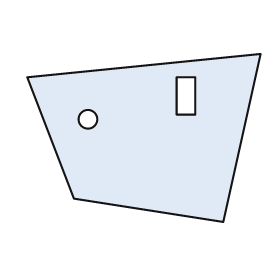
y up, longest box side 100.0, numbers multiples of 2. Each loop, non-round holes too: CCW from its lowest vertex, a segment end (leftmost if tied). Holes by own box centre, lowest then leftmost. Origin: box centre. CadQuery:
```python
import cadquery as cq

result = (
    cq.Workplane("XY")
    .moveTo(34.0, -36.0)
    .lineTo(50.0, 36.0)
    .lineTo(-50.0, 26.0)
    .lineTo(-30.0, -26.0)
    .close()
    .moveTo(-24.0, 8.0)
    .circle(4.0)
    .moveTo(14.0, 10.0)
    .lineTo(22.0, 10.0)
    .lineTo(22.0, 26.0)
    .lineTo(14.0, 26.0)
    .close()
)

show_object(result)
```